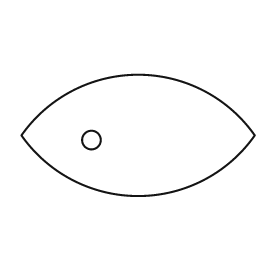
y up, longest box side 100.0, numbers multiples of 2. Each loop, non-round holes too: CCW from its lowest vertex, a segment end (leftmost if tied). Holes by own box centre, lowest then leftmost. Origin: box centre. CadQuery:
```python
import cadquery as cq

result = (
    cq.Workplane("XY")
    .moveTo(-50.0, 0.0)
    .threePointArc((0.0, -26.0), (50.0, 0.0))
    .threePointArc((0.0, 26.0), (-50.0, 0.0))
    .close()
    .moveTo(-20.0, -2.0)
    .circle(4.0)
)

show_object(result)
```